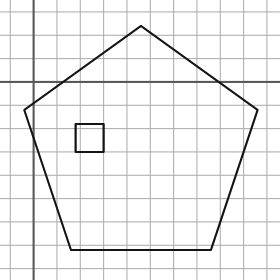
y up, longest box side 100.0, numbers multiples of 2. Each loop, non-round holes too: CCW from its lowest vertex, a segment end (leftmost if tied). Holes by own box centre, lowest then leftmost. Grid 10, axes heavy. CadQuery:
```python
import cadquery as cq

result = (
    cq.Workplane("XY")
    .moveTo(16.0, -72.0)
    .lineTo(76.0, -72.0)
    .lineTo(96.0, -12.0)
    .lineTo(46.0, 24.0)
    .lineTo(-4.0, -12.0)
    .close()
    .moveTo(18.0, -30.0)
    .lineTo(30.0, -30.0)
    .lineTo(30.0, -18.0)
    .lineTo(18.0, -18.0)
    .close()
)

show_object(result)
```